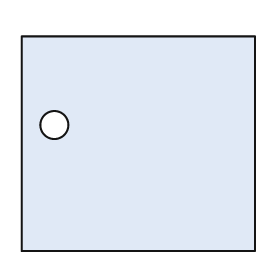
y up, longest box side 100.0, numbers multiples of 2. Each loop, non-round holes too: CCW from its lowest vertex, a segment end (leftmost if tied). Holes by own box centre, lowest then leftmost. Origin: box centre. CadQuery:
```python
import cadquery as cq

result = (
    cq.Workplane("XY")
    .moveTo(-50.0, -46.0)
    .lineTo(50.0, -46.0)
    .lineTo(50.0, 46.0)
    .lineTo(-50.0, 46.0)
    .close()
    .moveTo(-36.0, 8.0)
    .circle(6.0)
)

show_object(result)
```